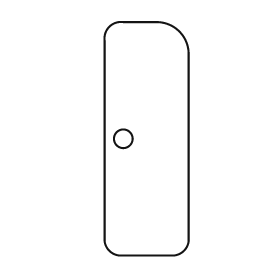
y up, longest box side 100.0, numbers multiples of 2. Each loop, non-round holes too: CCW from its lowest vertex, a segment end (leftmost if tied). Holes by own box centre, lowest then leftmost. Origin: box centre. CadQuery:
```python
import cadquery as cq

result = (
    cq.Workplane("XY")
    .moveTo(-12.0, -50.0)
    .lineTo(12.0, -50.0)
    .threePointArc((16.0, -48.0), (18.0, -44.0))
    .lineTo(18.0, 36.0)
    .threePointArc((14.0, 46.0), (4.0, 50.0))
    .lineTo(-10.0, 50.0)
    .threePointArc((-16.0, 48.0), (-18.0, 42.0))
    .lineTo(-18.0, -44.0)
    .threePointArc((-16.0, -48.0), (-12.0, -50.0))
    .close()
    .moveTo(-10.0, 0.0)
    .circle(4.0)
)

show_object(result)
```